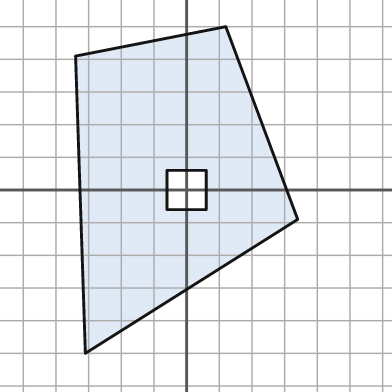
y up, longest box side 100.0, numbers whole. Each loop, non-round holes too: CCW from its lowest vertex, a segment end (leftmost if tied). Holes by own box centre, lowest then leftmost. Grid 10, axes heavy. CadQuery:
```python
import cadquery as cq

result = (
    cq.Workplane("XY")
    .moveTo(-31.0, -50.0)
    .lineTo(34.0, -9.0)
    .lineTo(12.0, 50.0)
    .lineTo(-34.0, 41.0)
    .close()
    .moveTo(-6.0, -6.0)
    .lineTo(6.0, -6.0)
    .lineTo(6.0, 6.0)
    .lineTo(-6.0, 6.0)
    .close()
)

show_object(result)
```